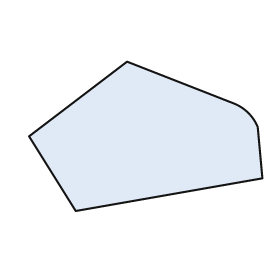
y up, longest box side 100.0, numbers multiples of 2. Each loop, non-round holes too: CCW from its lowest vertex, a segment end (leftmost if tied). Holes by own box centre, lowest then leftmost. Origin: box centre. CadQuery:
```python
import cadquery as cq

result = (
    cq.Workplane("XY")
    .moveTo(-30.0, -32.0)
    .lineTo(50.0, -18.0)
    .lineTo(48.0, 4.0)
    .threePointArc((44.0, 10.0), (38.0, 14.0))
    .lineTo(-8.0, 32.0)
    .lineTo(-50.0, 0.0)
    .close()
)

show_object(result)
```